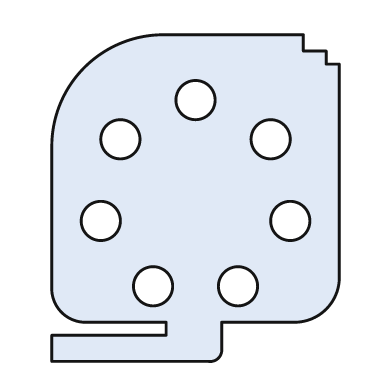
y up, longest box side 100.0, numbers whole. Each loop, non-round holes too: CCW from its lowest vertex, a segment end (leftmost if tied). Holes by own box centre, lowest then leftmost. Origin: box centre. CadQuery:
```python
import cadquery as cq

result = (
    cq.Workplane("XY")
    .moveTo(-44.0, -50.0)
    .lineTo(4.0, -50.0)
    .threePointArc((7.0, -49.0), (8.0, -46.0))
    .lineTo(8.0, -38.0)
    .lineTo(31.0, -38.0)
    .threePointArc((40.0, -34.0), (44.0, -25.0))
    .lineTo(44.0, 41.0)
    .lineTo(40.0, 41.0)
    .lineTo(40.0, 45.0)
    .lineTo(33.0, 45.0)
    .lineTo(33.0, 50.0)
    .lineTo(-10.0, 50.0)
    .threePointArc((-34.0, 40.0), (-44.0, 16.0))
    .lineTo(-44.0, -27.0)
    .threePointArc((-41.0, -35.0), (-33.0, -38.0))
    .lineTo(-9.0, -38.0)
    .lineTo(-9.0, -42.0)
    .lineTo(-44.0, -42.0)
    .close()
    .moveTo(-13.0, -27.0)
    .circle(6.0)
    .moveTo(13.0, -27.0)
    .circle(6.0)
    .moveTo(-29.0, -7.0)
    .circle(6.0)
    .moveTo(29.0, -7.0)
    .circle(6.0)
    .moveTo(-23.0, 18.0)
    .circle(6.0)
    .moveTo(23.0, 18.0)
    .circle(6.0)
    .moveTo(0.0, 30.0)
    .circle(6.0)
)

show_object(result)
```